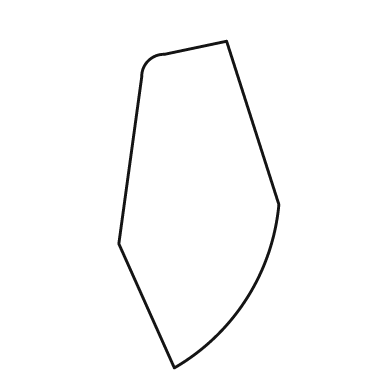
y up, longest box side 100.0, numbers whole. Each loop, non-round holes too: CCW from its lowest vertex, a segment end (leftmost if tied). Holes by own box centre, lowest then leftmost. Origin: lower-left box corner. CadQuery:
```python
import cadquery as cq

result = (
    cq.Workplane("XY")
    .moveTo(17.0, 0.0)
    .threePointArc((39.0, 21.0), (49.0, 50.0))
    .lineTo(33.0, 100.0)
    .lineTo(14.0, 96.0)
    .threePointArc((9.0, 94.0), (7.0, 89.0))
    .lineTo(0.0, 38.0)
    .close()
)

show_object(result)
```